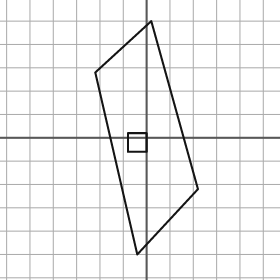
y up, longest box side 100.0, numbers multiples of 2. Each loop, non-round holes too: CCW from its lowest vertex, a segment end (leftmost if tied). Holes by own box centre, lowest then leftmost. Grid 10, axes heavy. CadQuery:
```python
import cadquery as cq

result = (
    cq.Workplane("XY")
    .moveTo(-4.0, -50.0)
    .lineTo(22.0, -22.0)
    .lineTo(2.0, 50.0)
    .lineTo(-22.0, 28.0)
    .close()
    .moveTo(-8.0, -6.0)
    .lineTo(0.0, -6.0)
    .lineTo(0.0, 2.0)
    .lineTo(-8.0, 2.0)
    .close()
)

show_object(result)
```